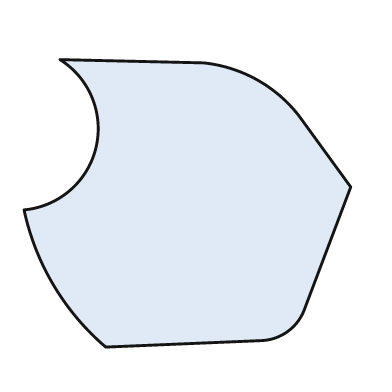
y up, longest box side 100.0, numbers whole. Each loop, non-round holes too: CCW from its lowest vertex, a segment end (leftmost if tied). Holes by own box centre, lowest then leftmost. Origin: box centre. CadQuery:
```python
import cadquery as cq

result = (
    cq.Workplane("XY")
    .moveTo(-25.0, -44.0)
    .lineTo(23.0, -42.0)
    .threePointArc((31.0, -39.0), (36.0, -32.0))
    .lineTo(50.0, 5.0)
    .lineTo(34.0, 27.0)
    .threePointArc((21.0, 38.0), (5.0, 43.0))
    .lineTo(-39.0, 44.0)
    .threePointArc((-28.0, 17.0), (-50.0, -2.0))
    .threePointArc((-41.0, -25.0), (-25.0, -44.0))
    .close()
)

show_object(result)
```